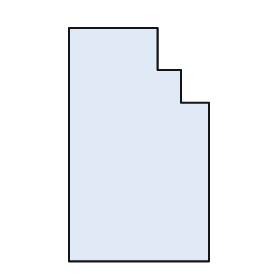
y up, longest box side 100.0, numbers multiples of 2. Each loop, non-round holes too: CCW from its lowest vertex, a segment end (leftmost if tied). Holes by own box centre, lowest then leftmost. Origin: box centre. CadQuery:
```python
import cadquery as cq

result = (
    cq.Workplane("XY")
    .moveTo(-30.0, -50.0)
    .lineTo(30.0, -50.0)
    .lineTo(30.0, 18.0)
    .lineTo(18.0, 18.0)
    .lineTo(18.0, 32.0)
    .lineTo(8.0, 32.0)
    .lineTo(8.0, 50.0)
    .lineTo(-30.0, 50.0)
    .close()
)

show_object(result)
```